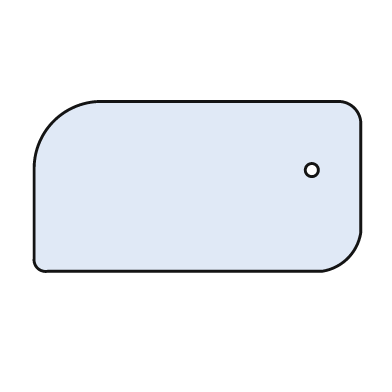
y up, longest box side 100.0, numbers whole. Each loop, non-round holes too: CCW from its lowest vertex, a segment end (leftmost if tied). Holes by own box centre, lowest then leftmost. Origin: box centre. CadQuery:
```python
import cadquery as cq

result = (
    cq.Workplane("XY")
    .moveTo(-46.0, -26.0)
    .lineTo(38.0, -26.0)
    .threePointArc((46.0, -22.0), (50.0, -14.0))
    .lineTo(50.0, 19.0)
    .threePointArc((48.0, 24.0), (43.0, 26.0))
    .lineTo(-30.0, 26.0)
    .threePointArc((-44.0, 20.0), (-50.0, 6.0))
    .lineTo(-50.0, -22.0)
    .threePointArc((-49.0, -25.0), (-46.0, -26.0))
    .close()
    .moveTo(35.0, 5.0)
    .circle(2.0)
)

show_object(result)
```